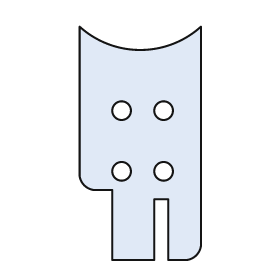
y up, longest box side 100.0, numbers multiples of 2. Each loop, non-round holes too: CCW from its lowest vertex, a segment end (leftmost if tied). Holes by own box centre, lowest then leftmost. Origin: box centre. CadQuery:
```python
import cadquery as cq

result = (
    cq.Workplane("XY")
    .moveTo(-12.0, -50.0)
    .lineTo(6.0, -50.0)
    .lineTo(6.0, -24.0)
    .lineTo(12.0, -24.0)
    .lineTo(12.0, -50.0)
    .lineTo(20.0, -50.0)
    .threePointArc((24.0, -48.0), (26.0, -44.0))
    .lineTo(26.0, 50.0)
    .threePointArc((0.0, 40.0), (-26.0, 50.0))
    .lineTo(-26.0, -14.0)
    .threePointArc((-24.0, -18.0), (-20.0, -20.0))
    .lineTo(-12.0, -20.0)
    .close()
    .moveTo(-8.0, -12.0)
    .circle(4.0)
    .moveTo(10.0, -12.0)
    .circle(4.0)
    .moveTo(-8.0, 14.0)
    .circle(4.0)
    .moveTo(10.0, 14.0)
    .circle(4.0)
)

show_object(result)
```